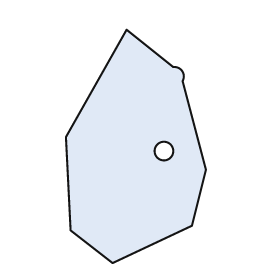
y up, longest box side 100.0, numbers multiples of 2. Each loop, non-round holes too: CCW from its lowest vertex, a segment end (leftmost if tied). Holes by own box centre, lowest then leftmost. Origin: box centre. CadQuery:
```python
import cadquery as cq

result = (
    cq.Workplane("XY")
    .moveTo(-10.0, -50.0)
    .lineTo(24.0, -34.0)
    .lineTo(30.0, -10.0)
    .lineTo(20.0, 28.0)
    .threePointArc((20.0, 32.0), (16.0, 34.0))
    .lineTo(-4.0, 50.0)
    .lineTo(-30.0, 4.0)
    .lineTo(-28.0, -36.0)
    .close()
    .moveTo(12.0, -2.0)
    .circle(4.0)
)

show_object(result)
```